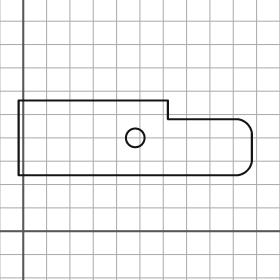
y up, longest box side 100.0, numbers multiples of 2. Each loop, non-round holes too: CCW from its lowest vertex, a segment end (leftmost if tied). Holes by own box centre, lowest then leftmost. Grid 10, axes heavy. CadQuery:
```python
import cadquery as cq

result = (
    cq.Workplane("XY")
    .moveTo(-2.0, 24.0)
    .lineTo(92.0, 24.0)
    .threePointArc((96.0, 26.0), (98.0, 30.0))
    .lineTo(98.0, 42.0)
    .threePointArc((96.0, 46.0), (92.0, 48.0))
    .lineTo(62.0, 48.0)
    .lineTo(62.0, 56.0)
    .lineTo(-2.0, 56.0)
    .close()
    .moveTo(48.0, 40.0)
    .circle(4.0)
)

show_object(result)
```